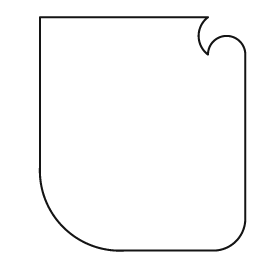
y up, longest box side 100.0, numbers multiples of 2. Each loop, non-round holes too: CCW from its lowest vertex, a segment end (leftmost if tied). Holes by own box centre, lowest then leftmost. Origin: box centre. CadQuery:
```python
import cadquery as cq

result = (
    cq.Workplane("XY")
    .moveTo(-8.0, -50.0)
    .lineTo(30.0, -50.0)
    .threePointArc((40.0, -46.0), (44.0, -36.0))
    .lineTo(44.0, 34.0)
    .threePointArc((36.0, 42.0), (28.0, 34.0))
    .threePointArc((24.0, 42.0), (28.0, 50.0))
    .lineTo(-44.0, 50.0)
    .lineTo(-44.0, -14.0)
    .threePointArc((-34.0, -40.0), (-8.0, -50.0))
    .close()
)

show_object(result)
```